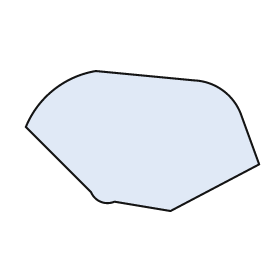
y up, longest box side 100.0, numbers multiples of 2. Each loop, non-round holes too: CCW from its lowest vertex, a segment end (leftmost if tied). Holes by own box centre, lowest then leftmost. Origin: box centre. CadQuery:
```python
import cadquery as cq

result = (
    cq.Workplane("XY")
    .moveTo(12.0, -30.0)
    .lineTo(50.0, -10.0)
    .lineTo(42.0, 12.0)
    .threePointArc((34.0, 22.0), (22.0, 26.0))
    .lineTo(-20.0, 30.0)
    .threePointArc((-38.0, 22.0), (-50.0, 6.0))
    .lineTo(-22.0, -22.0)
    .threePointArc((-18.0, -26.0), (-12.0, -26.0))
    .close()
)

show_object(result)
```